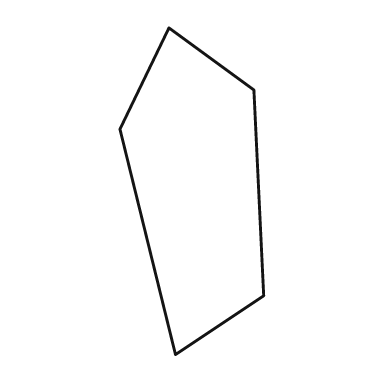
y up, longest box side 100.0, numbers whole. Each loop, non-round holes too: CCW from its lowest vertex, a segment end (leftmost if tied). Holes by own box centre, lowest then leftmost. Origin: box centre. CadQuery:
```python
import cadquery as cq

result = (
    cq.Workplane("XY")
    .moveTo(-5.0, -50.0)
    .lineTo(22.0, -32.0)
    .lineTo(19.0, 31.0)
    .lineTo(-7.0, 50.0)
    .lineTo(-22.0, 19.0)
    .close()
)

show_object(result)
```